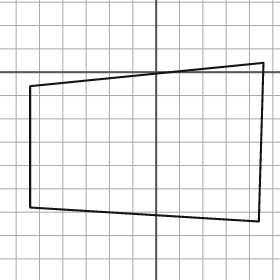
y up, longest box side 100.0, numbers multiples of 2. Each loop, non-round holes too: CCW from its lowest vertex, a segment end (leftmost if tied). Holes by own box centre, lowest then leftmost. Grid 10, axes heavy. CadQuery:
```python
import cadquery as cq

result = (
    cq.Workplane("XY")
    .moveTo(44.0, -64.0)
    .lineTo(46.0, 4.0)
    .lineTo(-54.0, -6.0)
    .lineTo(-54.0, -58.0)
    .close()
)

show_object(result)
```